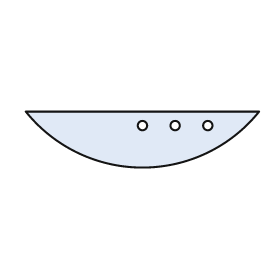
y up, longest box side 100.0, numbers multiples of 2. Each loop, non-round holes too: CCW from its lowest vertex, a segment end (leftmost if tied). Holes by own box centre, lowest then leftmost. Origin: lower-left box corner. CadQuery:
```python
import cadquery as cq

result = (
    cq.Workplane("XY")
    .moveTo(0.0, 24.0)
    .threePointArc((50.0, 0.0), (100.0, 24.0))
    .close()
    .moveTo(50.0, 18.0)
    .circle(2.0)
    .moveTo(64.0, 18.0)
    .circle(2.0)
    .moveTo(78.0, 18.0)
    .circle(2.0)
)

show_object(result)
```